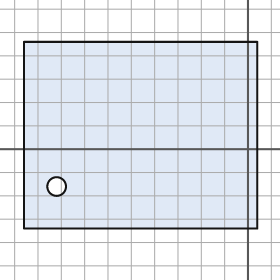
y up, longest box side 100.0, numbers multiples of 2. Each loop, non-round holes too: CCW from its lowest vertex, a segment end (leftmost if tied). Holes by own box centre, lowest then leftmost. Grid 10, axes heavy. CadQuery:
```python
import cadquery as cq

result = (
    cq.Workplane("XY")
    .moveTo(-96.0, -34.0)
    .lineTo(4.0, -34.0)
    .lineTo(4.0, 46.0)
    .lineTo(-96.0, 46.0)
    .close()
    .moveTo(-82.0, -16.0)
    .circle(4.0)
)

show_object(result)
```